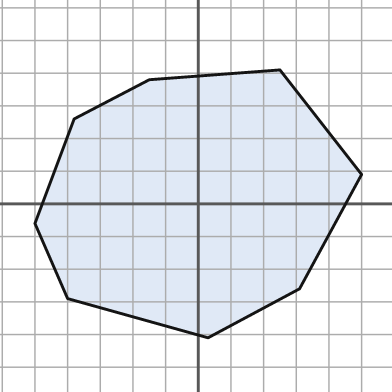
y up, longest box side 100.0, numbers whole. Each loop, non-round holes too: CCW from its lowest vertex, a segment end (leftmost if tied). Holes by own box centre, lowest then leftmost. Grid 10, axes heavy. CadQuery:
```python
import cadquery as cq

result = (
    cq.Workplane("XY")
    .moveTo(3.0, -41.0)
    .lineTo(31.0, -26.0)
    .lineTo(50.0, 9.0)
    .lineTo(25.0, 41.0)
    .lineTo(-15.0, 38.0)
    .lineTo(-38.0, 26.0)
    .lineTo(-50.0, -6.0)
    .lineTo(-40.0, -29.0)
    .close()
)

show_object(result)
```